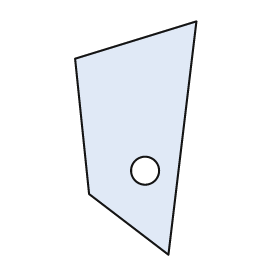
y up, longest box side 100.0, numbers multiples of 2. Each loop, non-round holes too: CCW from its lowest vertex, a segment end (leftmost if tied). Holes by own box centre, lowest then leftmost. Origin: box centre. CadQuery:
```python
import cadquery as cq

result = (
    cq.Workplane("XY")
    .moveTo(14.0, -50.0)
    .lineTo(26.0, 50.0)
    .lineTo(-26.0, 34.0)
    .lineTo(-20.0, -24.0)
    .close()
    .moveTo(4.0, -14.0)
    .circle(6.0)
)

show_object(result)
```